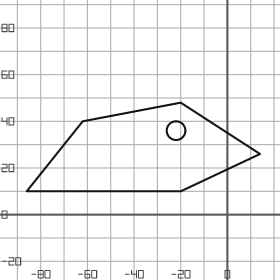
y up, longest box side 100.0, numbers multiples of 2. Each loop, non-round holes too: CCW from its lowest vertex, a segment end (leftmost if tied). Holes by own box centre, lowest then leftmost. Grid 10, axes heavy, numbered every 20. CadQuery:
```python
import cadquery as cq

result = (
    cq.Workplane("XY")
    .moveTo(-86.0, 10.0)
    .lineTo(-20.0, 10.0)
    .lineTo(14.0, 26.0)
    .lineTo(-20.0, 48.0)
    .lineTo(-62.0, 40.0)
    .close()
    .moveTo(-22.0, 36.0)
    .circle(4.0)
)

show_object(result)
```